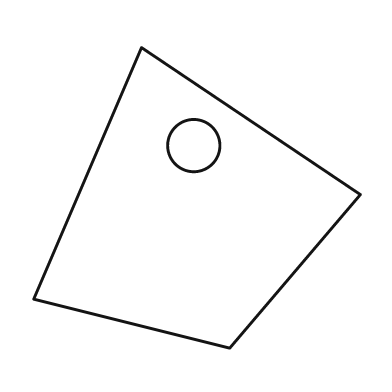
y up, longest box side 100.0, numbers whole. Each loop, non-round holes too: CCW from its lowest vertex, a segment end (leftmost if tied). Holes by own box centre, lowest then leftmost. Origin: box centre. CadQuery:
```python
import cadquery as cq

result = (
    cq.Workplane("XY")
    .moveTo(10.0, -46.0)
    .lineTo(50.0, 1.0)
    .lineTo(-17.0, 46.0)
    .lineTo(-50.0, -31.0)
    .close()
    .moveTo(-1.0, 16.0)
    .circle(8.0)
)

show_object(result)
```